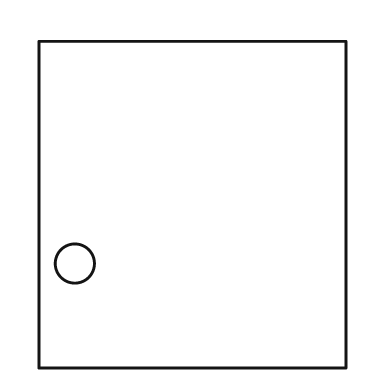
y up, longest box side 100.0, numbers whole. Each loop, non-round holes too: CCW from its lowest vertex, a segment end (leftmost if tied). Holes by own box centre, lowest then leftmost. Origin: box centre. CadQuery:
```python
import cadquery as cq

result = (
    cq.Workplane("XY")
    .moveTo(-47.0, -50.0)
    .lineTo(47.0, -50.0)
    .lineTo(47.0, 50.0)
    .lineTo(-47.0, 50.0)
    .close()
    .moveTo(-36.0, -18.0)
    .circle(6.0)
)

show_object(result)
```